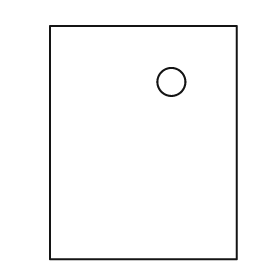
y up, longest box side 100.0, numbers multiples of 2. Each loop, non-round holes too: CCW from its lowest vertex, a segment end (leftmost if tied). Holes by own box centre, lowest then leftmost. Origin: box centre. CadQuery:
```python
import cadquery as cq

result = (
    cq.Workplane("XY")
    .moveTo(-40.0, -50.0)
    .lineTo(40.0, -50.0)
    .lineTo(40.0, 50.0)
    .lineTo(-40.0, 50.0)
    .close()
    .moveTo(12.0, 26.0)
    .circle(6.0)
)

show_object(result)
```